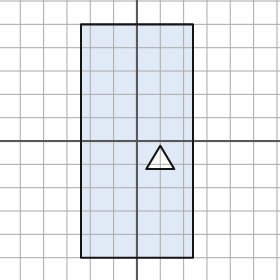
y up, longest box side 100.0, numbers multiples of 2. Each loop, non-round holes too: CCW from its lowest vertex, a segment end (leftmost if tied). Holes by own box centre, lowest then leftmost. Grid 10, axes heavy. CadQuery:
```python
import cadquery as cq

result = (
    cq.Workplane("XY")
    .moveTo(-24.0, -50.0)
    .lineTo(24.0, -50.0)
    .lineTo(24.0, 50.0)
    .lineTo(-24.0, 50.0)
    .close()
    .moveTo(4.0, -12.0)
    .lineTo(16.0, -12.0)
    .lineTo(10.0, -2.0)
    .close()
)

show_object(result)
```